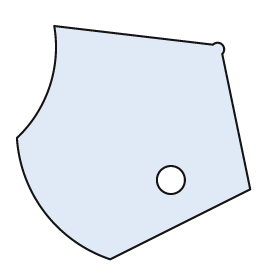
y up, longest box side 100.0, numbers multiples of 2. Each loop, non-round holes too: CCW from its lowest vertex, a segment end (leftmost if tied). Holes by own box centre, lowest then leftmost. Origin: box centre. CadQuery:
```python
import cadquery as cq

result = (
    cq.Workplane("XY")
    .moveTo(-10.0, -50.0)
    .lineTo(50.0, -20.0)
    .lineTo(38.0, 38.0)
    .threePointArc((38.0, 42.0), (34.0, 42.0))
    .lineTo(-34.0, 50.0)
    .threePointArc((-36.0, 24.0), (-50.0, 2.0))
    .threePointArc((-38.0, -30.0), (-10.0, -50.0))
    .close()
    .moveTo(16.0, -16.0)
    .circle(6.0)
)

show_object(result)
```